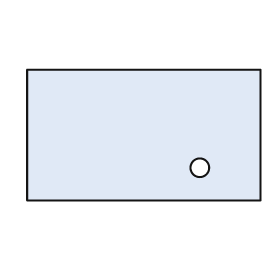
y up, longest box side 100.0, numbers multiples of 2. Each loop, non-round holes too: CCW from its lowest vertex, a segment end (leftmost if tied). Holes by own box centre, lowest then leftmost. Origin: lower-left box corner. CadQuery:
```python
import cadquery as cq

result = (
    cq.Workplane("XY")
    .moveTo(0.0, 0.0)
    .lineTo(100.0, 0.0)
    .lineTo(100.0, 56.0)
    .lineTo(0.0, 56.0)
    .close()
    .moveTo(74.0, 14.0)
    .circle(4.0)
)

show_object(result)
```